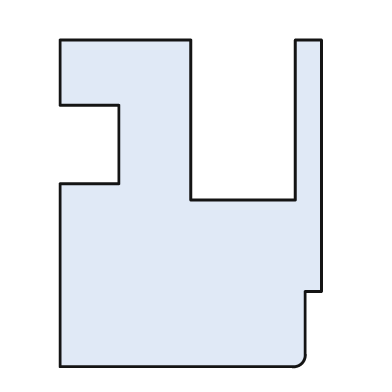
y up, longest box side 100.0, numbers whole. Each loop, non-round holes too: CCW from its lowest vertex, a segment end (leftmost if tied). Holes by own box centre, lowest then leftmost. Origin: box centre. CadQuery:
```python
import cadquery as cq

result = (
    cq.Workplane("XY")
    .moveTo(-40.0, -50.0)
    .lineTo(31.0, -50.0)
    .threePointArc((34.0, -49.0), (35.0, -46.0))
    .lineTo(35.0, -27.0)
    .lineTo(40.0, -27.0)
    .lineTo(40.0, 50.0)
    .lineTo(32.0, 50.0)
    .lineTo(32.0, 1.0)
    .lineTo(0.0, 1.0)
    .lineTo(0.0, 50.0)
    .lineTo(-40.0, 50.0)
    .lineTo(-40.0, 30.0)
    .lineTo(-22.0, 30.0)
    .lineTo(-22.0, 6.0)
    .lineTo(-40.0, 6.0)
    .close()
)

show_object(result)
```